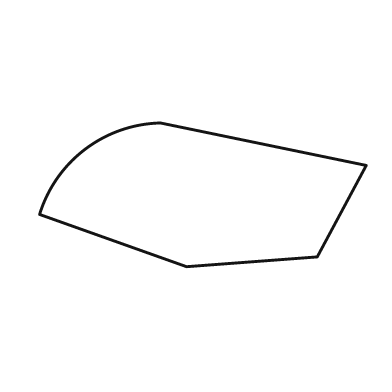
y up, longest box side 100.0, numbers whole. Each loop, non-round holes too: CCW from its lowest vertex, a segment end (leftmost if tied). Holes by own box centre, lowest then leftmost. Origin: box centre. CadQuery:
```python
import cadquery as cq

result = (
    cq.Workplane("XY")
    .moveTo(-5.0, -22.0)
    .lineTo(35.0, -19.0)
    .lineTo(50.0, 9.0)
    .lineTo(-13.0, 22.0)
    .threePointArc((-36.0, 14.0), (-50.0, -6.0))
    .close()
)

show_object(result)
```